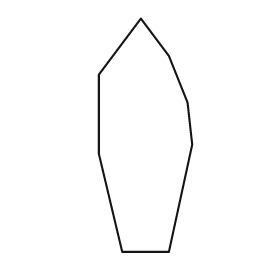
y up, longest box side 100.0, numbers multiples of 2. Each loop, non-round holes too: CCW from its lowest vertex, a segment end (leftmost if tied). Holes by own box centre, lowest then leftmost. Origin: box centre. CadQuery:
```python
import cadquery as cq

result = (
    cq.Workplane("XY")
    .moveTo(-10.0, -50.0)
    .lineTo(10.0, -50.0)
    .lineTo(20.0, -4.0)
    .lineTo(18.0, 14.0)
    .lineTo(10.0, 34.0)
    .lineTo(-2.0, 50.0)
    .lineTo(-20.0, 26.0)
    .lineTo(-20.0, -8.0)
    .close()
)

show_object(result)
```